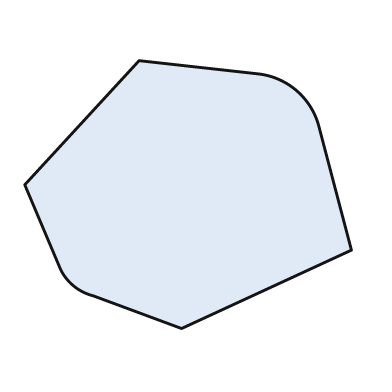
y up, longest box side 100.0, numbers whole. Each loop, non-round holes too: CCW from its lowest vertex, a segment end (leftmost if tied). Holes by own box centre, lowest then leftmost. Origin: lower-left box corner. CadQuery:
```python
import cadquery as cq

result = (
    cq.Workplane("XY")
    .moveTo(48.0, 0.0)
    .lineTo(100.0, 24.0)
    .lineTo(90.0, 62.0)
    .threePointArc((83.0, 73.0), (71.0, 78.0))
    .lineTo(35.0, 82.0)
    .lineTo(0.0, 44.0)
    .lineTo(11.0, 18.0)
    .threePointArc((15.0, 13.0), (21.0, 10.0))
    .close()
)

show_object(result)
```